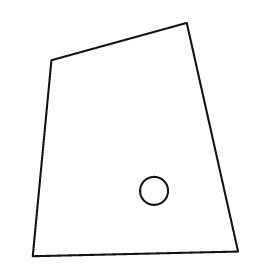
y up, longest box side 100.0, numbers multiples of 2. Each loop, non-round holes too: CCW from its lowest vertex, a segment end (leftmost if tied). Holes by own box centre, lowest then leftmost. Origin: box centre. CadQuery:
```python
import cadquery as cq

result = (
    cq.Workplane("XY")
    .moveTo(-44.0, -50.0)
    .lineTo(44.0, -48.0)
    .lineTo(22.0, 50.0)
    .lineTo(-36.0, 34.0)
    .close()
    .moveTo(8.0, -22.0)
    .circle(6.0)
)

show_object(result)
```